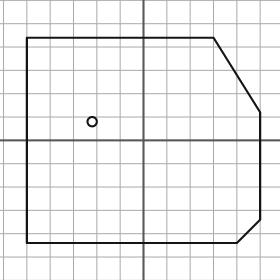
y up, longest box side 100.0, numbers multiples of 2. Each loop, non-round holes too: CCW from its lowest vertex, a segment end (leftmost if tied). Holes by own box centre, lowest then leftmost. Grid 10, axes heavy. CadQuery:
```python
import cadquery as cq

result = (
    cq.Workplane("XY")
    .moveTo(-50.0, -44.0)
    .lineTo(40.0, -44.0)
    .lineTo(50.0, -34.0)
    .lineTo(50.0, 12.0)
    .lineTo(30.0, 44.0)
    .lineTo(-50.0, 44.0)
    .close()
    .moveTo(-22.0, 8.0)
    .circle(2.0)
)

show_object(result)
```